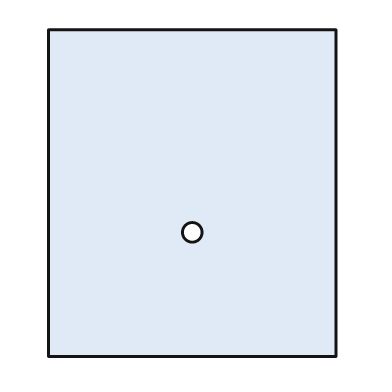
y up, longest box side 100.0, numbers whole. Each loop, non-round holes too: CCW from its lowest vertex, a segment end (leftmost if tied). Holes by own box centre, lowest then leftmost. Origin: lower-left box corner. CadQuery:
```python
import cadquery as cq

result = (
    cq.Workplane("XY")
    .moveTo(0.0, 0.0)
    .lineTo(88.0, 0.0)
    .lineTo(88.0, 100.0)
    .lineTo(0.0, 100.0)
    .close()
    .moveTo(44.0, 38.0)
    .circle(3.0)
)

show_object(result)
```